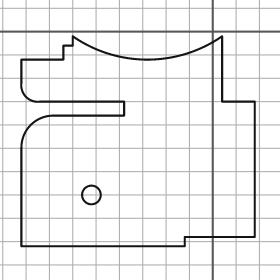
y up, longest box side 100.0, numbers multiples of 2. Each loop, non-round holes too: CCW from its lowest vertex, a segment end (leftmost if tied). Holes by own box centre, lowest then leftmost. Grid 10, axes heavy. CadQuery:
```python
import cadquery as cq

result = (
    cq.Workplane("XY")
    .moveTo(-82.0, -92.0)
    .lineTo(-12.0, -92.0)
    .lineTo(-12.0, -88.0)
    .lineTo(18.0, -88.0)
    .lineTo(18.0, -30.0)
    .lineTo(4.0, -30.0)
    .lineTo(4.0, -2.0)
    .threePointArc((-28.0, -12.0), (-60.0, -2.0))
    .lineTo(-60.0, -6.0)
    .lineTo(-64.0, -6.0)
    .lineTo(-64.0, -12.0)
    .lineTo(-82.0, -12.0)
    .lineTo(-82.0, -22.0)
    .threePointArc((-80.0, -28.0), (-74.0, -30.0))
    .lineTo(-38.0, -30.0)
    .lineTo(-38.0, -36.0)
    .lineTo(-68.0, -36.0)
    .threePointArc((-78.0, -40.0), (-82.0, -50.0))
    .close()
    .moveTo(-52.0, -70.0)
    .circle(4.0)
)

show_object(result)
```